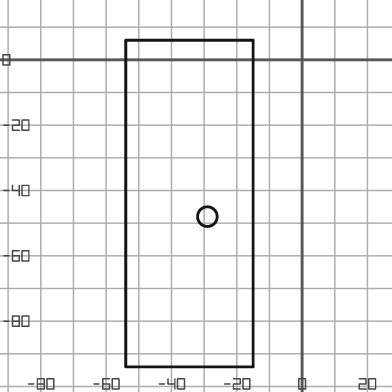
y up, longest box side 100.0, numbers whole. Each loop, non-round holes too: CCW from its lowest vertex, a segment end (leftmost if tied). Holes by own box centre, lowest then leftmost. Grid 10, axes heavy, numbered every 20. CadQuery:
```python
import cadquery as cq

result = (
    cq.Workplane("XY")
    .moveTo(-54.0, -94.0)
    .lineTo(-15.0, -94.0)
    .lineTo(-15.0, 6.0)
    .lineTo(-54.0, 6.0)
    .close()
    .moveTo(-29.0, -48.0)
    .circle(3.0)
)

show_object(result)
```